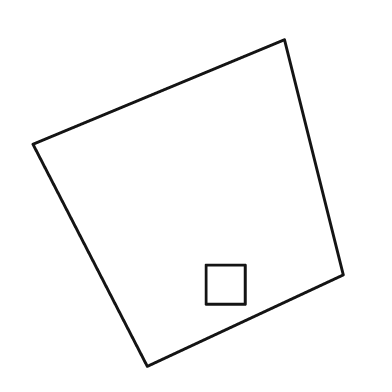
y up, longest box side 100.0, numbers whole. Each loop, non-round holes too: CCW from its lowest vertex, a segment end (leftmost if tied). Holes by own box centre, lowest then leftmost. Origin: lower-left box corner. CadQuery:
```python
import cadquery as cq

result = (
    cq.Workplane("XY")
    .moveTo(35.0, 0.0)
    .lineTo(95.0, 28.0)
    .lineTo(77.0, 100.0)
    .lineTo(0.0, 68.0)
    .close()
    .moveTo(53.0, 19.0)
    .lineTo(65.0, 19.0)
    .lineTo(65.0, 31.0)
    .lineTo(53.0, 31.0)
    .close()
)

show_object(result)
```